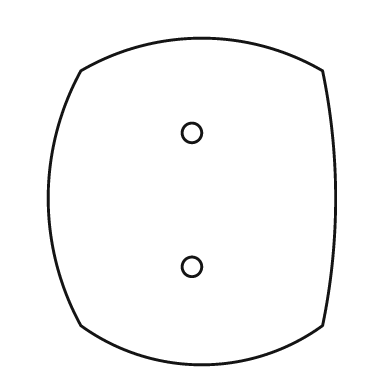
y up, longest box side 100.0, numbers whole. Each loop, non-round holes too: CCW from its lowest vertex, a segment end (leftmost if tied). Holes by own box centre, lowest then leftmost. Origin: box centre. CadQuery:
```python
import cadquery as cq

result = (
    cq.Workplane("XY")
    .moveTo(-34.0, -38.0)
    .threePointArc((3.0, -50.0), (40.0, -38.0))
    .threePointArc((44.0, 1.0), (40.0, 40.0))
    .threePointArc((3.0, 50.0), (-34.0, 40.0))
    .threePointArc((-44.0, 1.0), (-34.0, -38.0))
    .close()
    .moveTo(0.0, -20.0)
    .circle(3.0)
    .moveTo(0.0, 21.0)
    .circle(3.0)
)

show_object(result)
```